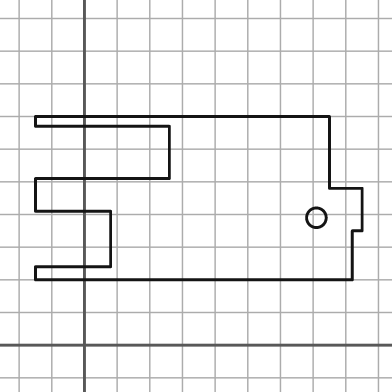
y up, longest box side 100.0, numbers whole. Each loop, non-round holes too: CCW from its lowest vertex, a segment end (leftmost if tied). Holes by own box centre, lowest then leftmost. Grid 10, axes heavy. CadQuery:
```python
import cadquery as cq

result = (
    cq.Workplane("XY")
    .moveTo(-15.0, 20.0)
    .lineTo(82.0, 20.0)
    .lineTo(82.0, 35.0)
    .lineTo(85.0, 35.0)
    .lineTo(85.0, 48.0)
    .lineTo(75.0, 48.0)
    .lineTo(75.0, 70.0)
    .lineTo(-15.0, 70.0)
    .lineTo(-15.0, 67.0)
    .lineTo(26.0, 67.0)
    .lineTo(26.0, 51.0)
    .lineTo(-15.0, 51.0)
    .lineTo(-15.0, 41.0)
    .lineTo(8.0, 41.0)
    .lineTo(8.0, 24.0)
    .lineTo(-15.0, 24.0)
    .close()
    .moveTo(71.0, 39.0)
    .circle(3.0)
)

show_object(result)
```